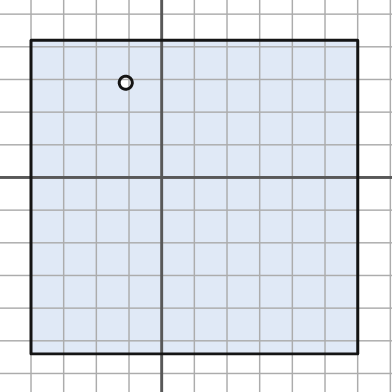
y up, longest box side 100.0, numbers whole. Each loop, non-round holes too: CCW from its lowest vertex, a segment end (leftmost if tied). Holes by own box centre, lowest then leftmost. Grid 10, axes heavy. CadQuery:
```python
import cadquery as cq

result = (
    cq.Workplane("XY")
    .moveTo(-40.0, -54.0)
    .lineTo(60.0, -54.0)
    .lineTo(60.0, 42.0)
    .lineTo(-40.0, 42.0)
    .close()
    .moveTo(-11.0, 29.0)
    .circle(2.0)
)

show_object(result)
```